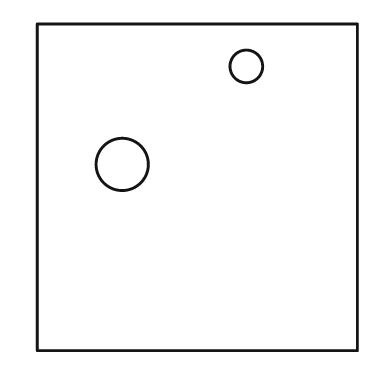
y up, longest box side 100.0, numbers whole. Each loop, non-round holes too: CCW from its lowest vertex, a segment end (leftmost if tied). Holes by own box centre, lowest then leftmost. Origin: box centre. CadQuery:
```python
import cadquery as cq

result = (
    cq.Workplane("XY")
    .moveTo(-49.0, -50.0)
    .lineTo(49.0, -50.0)
    .lineTo(49.0, 50.0)
    .lineTo(-49.0, 50.0)
    .close()
    .moveTo(-23.0, 7.0)
    .circle(8.0)
    .moveTo(15.0, 37.0)
    .circle(5.0)
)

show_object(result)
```